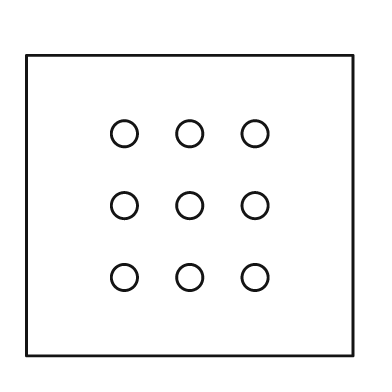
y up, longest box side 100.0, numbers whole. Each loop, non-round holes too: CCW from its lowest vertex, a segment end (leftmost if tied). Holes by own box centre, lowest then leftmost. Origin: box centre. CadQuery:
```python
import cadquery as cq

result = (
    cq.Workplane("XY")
    .moveTo(-50.0, -46.0)
    .lineTo(50.0, -46.0)
    .lineTo(50.0, 46.0)
    .lineTo(-50.0, 46.0)
    .close()
    .moveTo(-20.0, -22.0)
    .circle(4.0)
    .moveTo(0.0, -22.0)
    .circle(4.0)
    .moveTo(20.0, -22.0)
    .circle(4.0)
    .moveTo(-20.0, 0.0)
    .circle(4.0)
    .moveTo(0.0, 0.0)
    .circle(4.0)
    .moveTo(20.0, 0.0)
    .circle(4.0)
    .moveTo(-20.0, 22.0)
    .circle(4.0)
    .moveTo(0.0, 22.0)
    .circle(4.0)
    .moveTo(20.0, 22.0)
    .circle(4.0)
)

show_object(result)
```